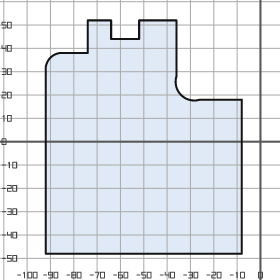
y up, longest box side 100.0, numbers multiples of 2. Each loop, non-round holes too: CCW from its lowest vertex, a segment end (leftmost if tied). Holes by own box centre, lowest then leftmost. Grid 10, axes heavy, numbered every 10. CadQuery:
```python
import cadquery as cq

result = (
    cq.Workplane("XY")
    .moveTo(-92.0, -48.0)
    .lineTo(-8.0, -48.0)
    .lineTo(-8.0, 18.0)
    .lineTo(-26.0, 18.0)
    .threePointArc((-34.0, 20.0), (-36.0, 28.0))
    .lineTo(-36.0, 52.0)
    .lineTo(-52.0, 52.0)
    .lineTo(-52.0, 44.0)
    .lineTo(-64.0, 44.0)
    .lineTo(-64.0, 52.0)
    .lineTo(-74.0, 52.0)
    .lineTo(-74.0, 38.0)
    .lineTo(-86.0, 38.0)
    .threePointArc((-90.0, 36.0), (-92.0, 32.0))
    .close()
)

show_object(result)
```